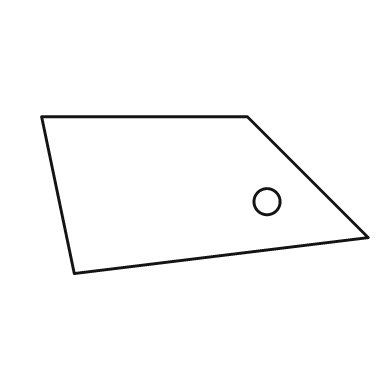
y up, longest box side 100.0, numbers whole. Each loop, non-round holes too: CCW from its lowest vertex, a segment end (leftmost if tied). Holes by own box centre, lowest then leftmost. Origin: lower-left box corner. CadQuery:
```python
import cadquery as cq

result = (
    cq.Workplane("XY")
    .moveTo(10.0, 0.0)
    .lineTo(100.0, 11.0)
    .lineTo(63.0, 48.0)
    .lineTo(0.0, 48.0)
    .close()
    .moveTo(69.0, 22.0)
    .circle(4.0)
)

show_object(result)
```